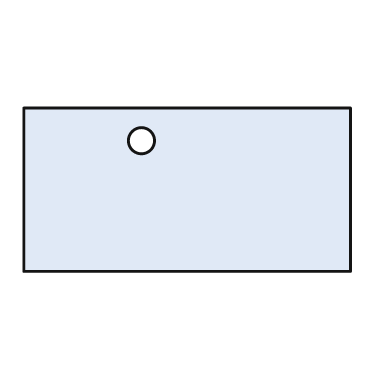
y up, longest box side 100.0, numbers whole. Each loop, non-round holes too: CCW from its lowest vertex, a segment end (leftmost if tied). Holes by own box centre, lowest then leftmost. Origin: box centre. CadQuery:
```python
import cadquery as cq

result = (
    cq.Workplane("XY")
    .moveTo(-50.0, -25.0)
    .lineTo(50.0, -25.0)
    .lineTo(50.0, 25.0)
    .lineTo(-50.0, 25.0)
    .close()
    .moveTo(-14.0, 15.0)
    .circle(4.0)
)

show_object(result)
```